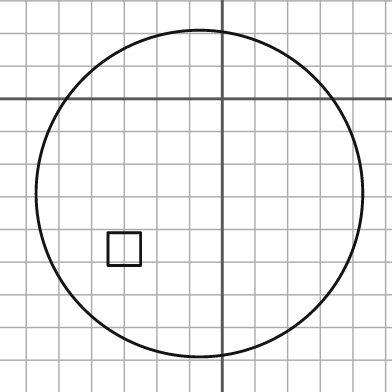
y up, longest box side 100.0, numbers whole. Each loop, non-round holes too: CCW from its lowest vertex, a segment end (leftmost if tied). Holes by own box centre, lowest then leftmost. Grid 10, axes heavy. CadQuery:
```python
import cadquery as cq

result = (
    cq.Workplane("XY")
    .moveTo(-7.0, -29.0)
    .circle(50.0)
    .moveTo(-35.0, -51.0)
    .lineTo(-25.0, -51.0)
    .lineTo(-25.0, -41.0)
    .lineTo(-35.0, -41.0)
    .close()
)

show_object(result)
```